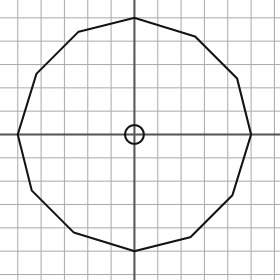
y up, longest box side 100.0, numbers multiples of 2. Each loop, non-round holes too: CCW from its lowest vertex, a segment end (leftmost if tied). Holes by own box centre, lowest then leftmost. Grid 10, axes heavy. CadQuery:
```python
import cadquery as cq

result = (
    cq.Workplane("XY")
    .moveTo(0.0, -50.0)
    .lineTo(24.0, -44.0)
    .lineTo(42.0, -26.0)
    .lineTo(50.0, 0.0)
    .lineTo(44.0, 24.0)
    .lineTo(26.0, 42.0)
    .lineTo(0.0, 50.0)
    .lineTo(-24.0, 44.0)
    .lineTo(-42.0, 26.0)
    .lineTo(-50.0, 0.0)
    .lineTo(-44.0, -24.0)
    .lineTo(-26.0, -42.0)
    .close()
    .moveTo(0.0, 0.0)
    .circle(4.0)
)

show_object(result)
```